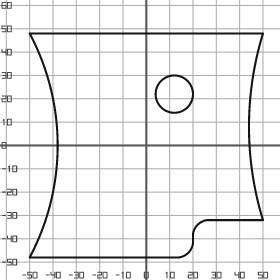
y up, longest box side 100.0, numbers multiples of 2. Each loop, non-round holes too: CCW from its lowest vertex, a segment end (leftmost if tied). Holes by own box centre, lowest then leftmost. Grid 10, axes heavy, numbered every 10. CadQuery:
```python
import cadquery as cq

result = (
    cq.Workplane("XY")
    .moveTo(-50.0, -48.0)
    .lineTo(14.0, -48.0)
    .threePointArc((18.0, -46.0), (20.0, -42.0))
    .lineTo(20.0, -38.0)
    .threePointArc((22.0, -34.0), (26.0, -32.0))
    .lineTo(50.0, -32.0)
    .threePointArc((44.0, 8.0), (50.0, 48.0))
    .lineTo(-50.0, 48.0)
    .threePointArc((-38.0, 0.0), (-50.0, -48.0))
    .close()
    .moveTo(12.0, 22.0)
    .circle(8.0)
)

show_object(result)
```